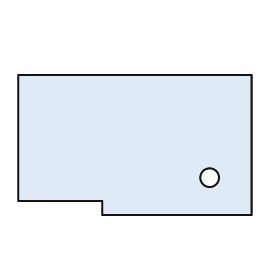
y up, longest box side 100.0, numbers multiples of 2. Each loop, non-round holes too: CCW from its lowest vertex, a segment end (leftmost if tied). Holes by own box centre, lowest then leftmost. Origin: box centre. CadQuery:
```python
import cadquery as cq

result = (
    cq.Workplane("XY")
    .moveTo(-14.0, -30.0)
    .lineTo(50.0, -30.0)
    .lineTo(50.0, 30.0)
    .lineTo(-50.0, 30.0)
    .lineTo(-50.0, -24.0)
    .lineTo(-14.0, -24.0)
    .close()
    .moveTo(32.0, -14.0)
    .circle(4.0)
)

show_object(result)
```